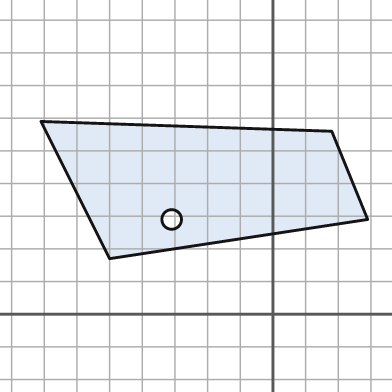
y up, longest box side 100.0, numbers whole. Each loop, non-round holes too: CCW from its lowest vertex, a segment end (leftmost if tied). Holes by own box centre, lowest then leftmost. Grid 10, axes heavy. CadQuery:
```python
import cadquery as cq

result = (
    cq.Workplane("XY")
    .moveTo(-50.0, 17.0)
    .lineTo(29.0, 29.0)
    .lineTo(18.0, 56.0)
    .lineTo(-71.0, 59.0)
    .close()
    .moveTo(-31.0, 29.0)
    .circle(3.0)
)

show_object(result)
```